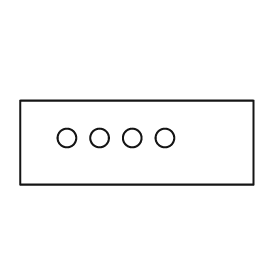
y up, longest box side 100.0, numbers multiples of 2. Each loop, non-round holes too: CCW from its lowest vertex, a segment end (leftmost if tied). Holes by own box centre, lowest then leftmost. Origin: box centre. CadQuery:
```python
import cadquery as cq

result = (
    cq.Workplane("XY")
    .moveTo(-50.0, -18.0)
    .lineTo(50.0, -18.0)
    .lineTo(50.0, 18.0)
    .lineTo(-50.0, 18.0)
    .close()
    .moveTo(-30.0, 2.0)
    .circle(4.0)
    .moveTo(-16.0, 2.0)
    .circle(4.0)
    .moveTo(-2.0, 2.0)
    .circle(4.0)
    .moveTo(12.0, 2.0)
    .circle(4.0)
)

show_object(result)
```